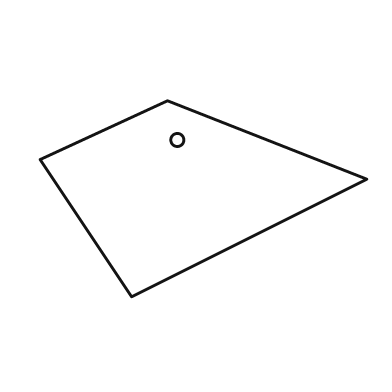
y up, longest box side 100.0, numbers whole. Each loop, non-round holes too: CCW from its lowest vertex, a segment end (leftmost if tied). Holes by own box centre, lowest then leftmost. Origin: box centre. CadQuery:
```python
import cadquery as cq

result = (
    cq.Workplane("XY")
    .moveTo(-22.0, -30.0)
    .lineTo(50.0, 6.0)
    .lineTo(-11.0, 30.0)
    .lineTo(-50.0, 12.0)
    .close()
    .moveTo(-8.0, 18.0)
    .circle(2.0)
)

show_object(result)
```